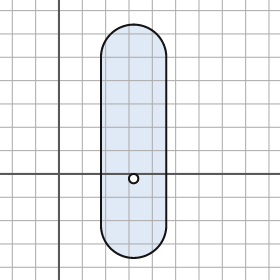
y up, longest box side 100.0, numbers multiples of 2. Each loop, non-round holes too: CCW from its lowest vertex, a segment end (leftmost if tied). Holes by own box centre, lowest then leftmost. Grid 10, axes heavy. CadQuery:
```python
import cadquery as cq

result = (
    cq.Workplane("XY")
    .moveTo(18.0, -22.0)
    .threePointArc((32.0, -36.0), (46.0, -22.0))
    .lineTo(46.0, 50.0)
    .threePointArc((32.0, 64.0), (18.0, 50.0))
    .close()
    .moveTo(32.0, -2.0)
    .circle(2.0)
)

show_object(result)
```